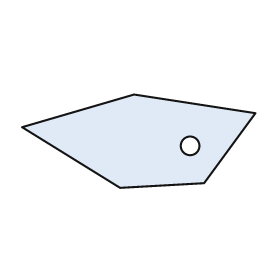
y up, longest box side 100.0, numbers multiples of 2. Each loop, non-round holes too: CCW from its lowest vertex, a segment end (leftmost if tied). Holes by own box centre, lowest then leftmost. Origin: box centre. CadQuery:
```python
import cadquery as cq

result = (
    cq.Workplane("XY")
    .moveTo(-8.0, -20.0)
    .lineTo(28.0, -18.0)
    .lineTo(50.0, 12.0)
    .lineTo(-2.0, 20.0)
    .lineTo(-50.0, 6.0)
    .close()
    .moveTo(22.0, -2.0)
    .circle(4.0)
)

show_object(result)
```